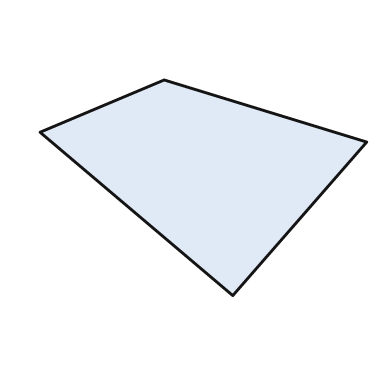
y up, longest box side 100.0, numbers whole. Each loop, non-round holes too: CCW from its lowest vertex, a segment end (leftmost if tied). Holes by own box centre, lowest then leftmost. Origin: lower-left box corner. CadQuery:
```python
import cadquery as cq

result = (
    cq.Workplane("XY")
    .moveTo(59.0, 0.0)
    .lineTo(100.0, 47.0)
    .lineTo(38.0, 66.0)
    .lineTo(0.0, 50.0)
    .close()
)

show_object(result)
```